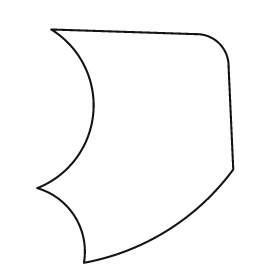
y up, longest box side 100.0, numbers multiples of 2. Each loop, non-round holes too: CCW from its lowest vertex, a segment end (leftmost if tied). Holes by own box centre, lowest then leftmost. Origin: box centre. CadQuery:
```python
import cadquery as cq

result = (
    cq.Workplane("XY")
    .moveTo(-22.0, -50.0)
    .threePointArc((14.0, -36.0), (42.0, -10.0))
    .lineTo(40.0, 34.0)
    .threePointArc((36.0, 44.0), (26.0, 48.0))
    .lineTo(-36.0, 50.0)
    .threePointArc((-18.0, 14.0), (-42.0, -18.0))
    .threePointArc((-26.0, -30.0), (-22.0, -50.0))
    .close()
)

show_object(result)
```